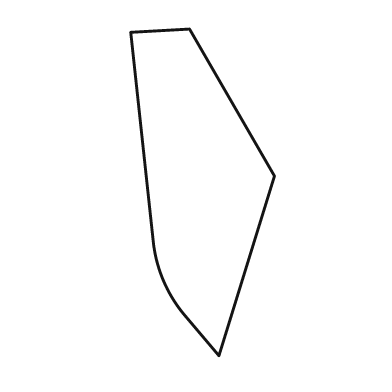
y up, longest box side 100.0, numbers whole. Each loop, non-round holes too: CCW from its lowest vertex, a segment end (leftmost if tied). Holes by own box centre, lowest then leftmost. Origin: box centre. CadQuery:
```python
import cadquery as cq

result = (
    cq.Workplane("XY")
    .moveTo(5.0, -50.0)
    .lineTo(22.0, 5.0)
    .lineTo(-4.0, 50.0)
    .lineTo(-22.0, 49.0)
    .lineTo(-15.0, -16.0)
    .threePointArc((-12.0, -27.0), (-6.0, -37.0))
    .close()
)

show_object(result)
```